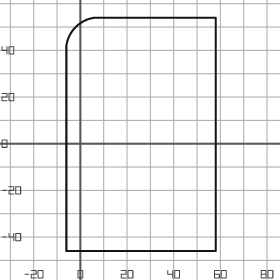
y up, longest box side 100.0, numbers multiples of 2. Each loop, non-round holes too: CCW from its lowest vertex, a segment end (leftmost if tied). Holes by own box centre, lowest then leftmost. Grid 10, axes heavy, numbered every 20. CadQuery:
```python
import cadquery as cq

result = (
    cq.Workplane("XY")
    .moveTo(-6.0, -46.0)
    .lineTo(58.0, -46.0)
    .lineTo(58.0, 54.0)
    .lineTo(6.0, 54.0)
    .threePointArc((-2.0, 50.0), (-6.0, 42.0))
    .close()
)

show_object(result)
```